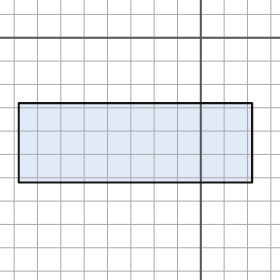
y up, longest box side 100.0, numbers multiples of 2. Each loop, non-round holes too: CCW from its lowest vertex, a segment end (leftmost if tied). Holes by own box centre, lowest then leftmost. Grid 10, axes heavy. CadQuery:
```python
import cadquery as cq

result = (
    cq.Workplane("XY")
    .moveTo(-78.0, -62.0)
    .lineTo(22.0, -62.0)
    .lineTo(22.0, -28.0)
    .lineTo(-78.0, -28.0)
    .close()
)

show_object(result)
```